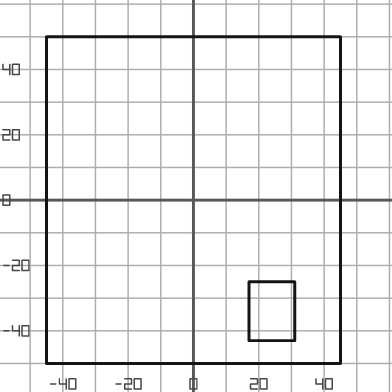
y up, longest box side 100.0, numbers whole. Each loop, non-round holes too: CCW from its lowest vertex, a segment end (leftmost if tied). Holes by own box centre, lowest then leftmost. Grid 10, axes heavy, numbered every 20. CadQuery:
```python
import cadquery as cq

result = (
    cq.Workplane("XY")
    .moveTo(-45.0, -50.0)
    .lineTo(45.0, -50.0)
    .lineTo(45.0, 50.0)
    .lineTo(-45.0, 50.0)
    .close()
    .moveTo(17.0, -43.0)
    .lineTo(31.0, -43.0)
    .lineTo(31.0, -25.0)
    .lineTo(17.0, -25.0)
    .close()
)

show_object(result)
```